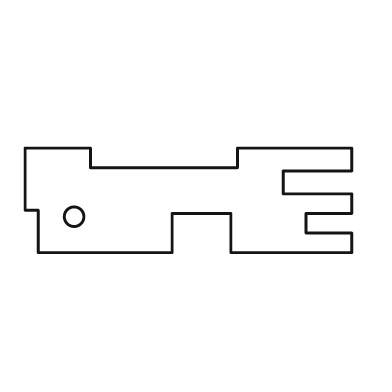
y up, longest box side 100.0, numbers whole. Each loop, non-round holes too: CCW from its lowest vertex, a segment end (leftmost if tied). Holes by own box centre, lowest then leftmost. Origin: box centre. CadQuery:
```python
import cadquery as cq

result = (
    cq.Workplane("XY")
    .moveTo(-46.0, -16.0)
    .lineTo(-5.0, -16.0)
    .lineTo(-5.0, -4.0)
    .lineTo(13.0, -4.0)
    .lineTo(13.0, -16.0)
    .lineTo(50.0, -16.0)
    .lineTo(50.0, -10.0)
    .lineTo(36.0, -10.0)
    .lineTo(36.0, -4.0)
    .lineTo(50.0, -4.0)
    .lineTo(50.0, 2.0)
    .lineTo(29.0, 2.0)
    .lineTo(29.0, 9.0)
    .lineTo(50.0, 9.0)
    .lineTo(50.0, 16.0)
    .lineTo(15.0, 16.0)
    .lineTo(15.0, 10.0)
    .lineTo(-30.0, 10.0)
    .lineTo(-30.0, 16.0)
    .lineTo(-50.0, 16.0)
    .lineTo(-50.0, -3.0)
    .lineTo(-46.0, -3.0)
    .close()
    .moveTo(-35.0, -5.0)
    .circle(3.0)
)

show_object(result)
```